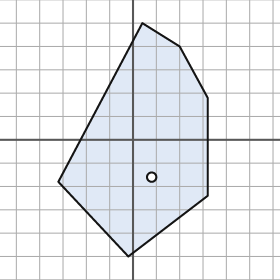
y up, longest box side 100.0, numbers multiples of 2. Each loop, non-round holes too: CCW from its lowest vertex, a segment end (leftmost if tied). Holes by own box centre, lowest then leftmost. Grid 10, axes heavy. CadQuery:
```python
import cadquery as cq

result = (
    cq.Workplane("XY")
    .moveTo(-2.0, -50.0)
    .lineTo(32.0, -24.0)
    .lineTo(32.0, 18.0)
    .lineTo(20.0, 40.0)
    .lineTo(4.0, 50.0)
    .lineTo(-32.0, -18.0)
    .close()
    .moveTo(8.0, -16.0)
    .circle(2.0)
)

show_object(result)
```